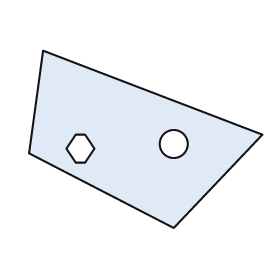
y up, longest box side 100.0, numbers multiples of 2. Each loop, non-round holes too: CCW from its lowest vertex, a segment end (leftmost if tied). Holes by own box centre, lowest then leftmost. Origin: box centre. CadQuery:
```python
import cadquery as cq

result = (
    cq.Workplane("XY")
    .moveTo(12.0, -38.0)
    .lineTo(50.0, 2.0)
    .lineTo(-44.0, 38.0)
    .lineTo(-50.0, -6.0)
    .close()
    .moveTo(-30.0, -10.0)
    .lineTo(-26.0, -10.0)
    .lineTo(-22.0, -4.0)
    .lineTo(-26.0, 2.0)
    .lineTo(-30.0, 2.0)
    .lineTo(-34.0, -4.0)
    .close()
    .moveTo(12.0, -2.0)
    .circle(6.0)
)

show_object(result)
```